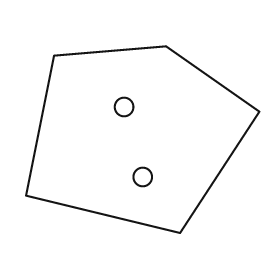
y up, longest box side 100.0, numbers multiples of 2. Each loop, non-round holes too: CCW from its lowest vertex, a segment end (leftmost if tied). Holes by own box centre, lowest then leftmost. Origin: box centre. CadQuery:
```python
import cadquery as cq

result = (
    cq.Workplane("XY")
    .moveTo(16.0, -40.0)
    .lineTo(50.0, 12.0)
    .lineTo(10.0, 40.0)
    .lineTo(-38.0, 36.0)
    .lineTo(-50.0, -24.0)
    .close()
    .moveTo(0.0, -16.0)
    .circle(4.0)
    .moveTo(-8.0, 14.0)
    .circle(4.0)
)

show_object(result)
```